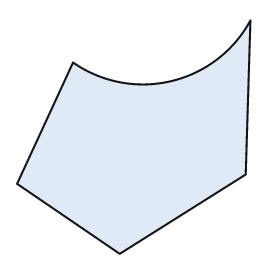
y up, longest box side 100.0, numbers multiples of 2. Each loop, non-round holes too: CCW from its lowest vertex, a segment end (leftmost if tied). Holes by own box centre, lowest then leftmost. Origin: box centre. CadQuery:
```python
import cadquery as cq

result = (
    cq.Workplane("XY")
    .moveTo(-6.0, -50.0)
    .lineTo(48.0, -16.0)
    .lineTo(50.0, 50.0)
    .threePointArc((16.0, 24.0), (-26.0, 32.0))
    .lineTo(-50.0, -20.0)
    .close()
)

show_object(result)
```